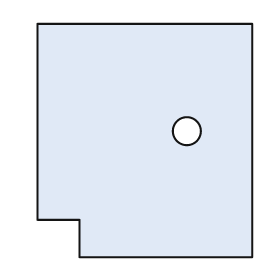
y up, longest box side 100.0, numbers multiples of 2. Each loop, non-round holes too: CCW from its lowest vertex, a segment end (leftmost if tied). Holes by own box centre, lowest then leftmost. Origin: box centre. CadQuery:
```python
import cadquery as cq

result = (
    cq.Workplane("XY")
    .moveTo(-28.0, -50.0)
    .lineTo(46.0, -50.0)
    .lineTo(46.0, 50.0)
    .lineTo(-46.0, 50.0)
    .lineTo(-46.0, -34.0)
    .lineTo(-28.0, -34.0)
    .close()
    .moveTo(18.0, 4.0)
    .circle(6.0)
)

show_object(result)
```